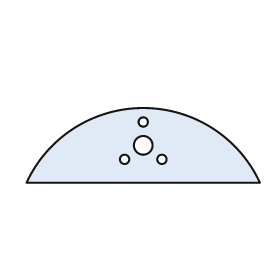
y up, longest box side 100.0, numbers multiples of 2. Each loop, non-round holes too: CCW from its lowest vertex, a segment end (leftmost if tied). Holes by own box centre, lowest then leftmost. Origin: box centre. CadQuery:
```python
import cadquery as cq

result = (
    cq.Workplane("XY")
    .moveTo(-50.0, -16.0)
    .lineTo(50.0, -16.0)
    .threePointArc((0.0, 16.0), (-50.0, -16.0))
    .close()
    .moveTo(-8.0, -6.0)
    .circle(2.0)
    .moveTo(8.0, -6.0)
    .circle(2.0)
    .moveTo(0.0, 0.0)
    .circle(4.0)
    .moveTo(0.0, 10.0)
    .circle(2.0)
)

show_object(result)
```